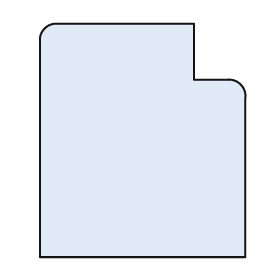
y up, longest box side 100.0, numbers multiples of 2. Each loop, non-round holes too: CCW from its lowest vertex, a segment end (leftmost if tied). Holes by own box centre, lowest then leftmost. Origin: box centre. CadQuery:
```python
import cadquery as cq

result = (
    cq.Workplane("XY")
    .moveTo(-44.0, -50.0)
    .lineTo(44.0, -50.0)
    .lineTo(44.0, 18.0)
    .threePointArc((42.0, 24.0), (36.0, 26.0))
    .lineTo(22.0, 26.0)
    .lineTo(22.0, 50.0)
    .lineTo(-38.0, 50.0)
    .threePointArc((-42.0, 48.0), (-44.0, 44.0))
    .close()
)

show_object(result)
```